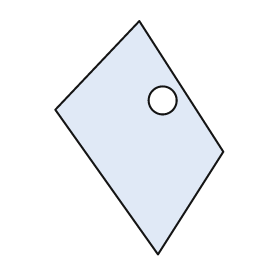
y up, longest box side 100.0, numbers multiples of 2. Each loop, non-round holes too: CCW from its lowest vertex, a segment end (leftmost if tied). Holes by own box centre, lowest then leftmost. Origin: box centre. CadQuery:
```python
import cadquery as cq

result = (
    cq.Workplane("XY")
    .moveTo(8.0, -50.0)
    .lineTo(36.0, -6.0)
    .lineTo(0.0, 50.0)
    .lineTo(-36.0, 12.0)
    .close()
    .moveTo(10.0, 16.0)
    .circle(6.0)
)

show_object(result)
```